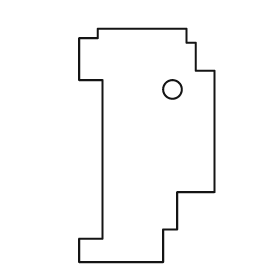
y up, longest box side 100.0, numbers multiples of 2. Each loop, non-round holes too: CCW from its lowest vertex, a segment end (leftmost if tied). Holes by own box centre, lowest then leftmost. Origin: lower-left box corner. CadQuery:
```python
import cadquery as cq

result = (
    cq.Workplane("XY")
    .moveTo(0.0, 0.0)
    .lineTo(36.0, 0.0)
    .lineTo(36.0, 14.0)
    .lineTo(42.0, 14.0)
    .lineTo(42.0, 30.0)
    .lineTo(58.0, 30.0)
    .lineTo(58.0, 82.0)
    .lineTo(50.0, 82.0)
    .lineTo(50.0, 94.0)
    .lineTo(46.0, 94.0)
    .lineTo(46.0, 100.0)
    .lineTo(8.0, 100.0)
    .lineTo(8.0, 96.0)
    .lineTo(0.0, 96.0)
    .lineTo(0.0, 78.0)
    .lineTo(10.0, 78.0)
    .lineTo(10.0, 10.0)
    .lineTo(0.0, 10.0)
    .close()
    .moveTo(40.0, 74.0)
    .circle(4.0)
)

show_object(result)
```